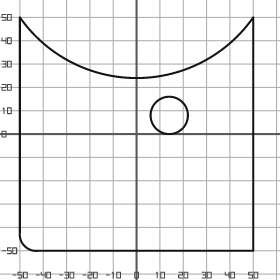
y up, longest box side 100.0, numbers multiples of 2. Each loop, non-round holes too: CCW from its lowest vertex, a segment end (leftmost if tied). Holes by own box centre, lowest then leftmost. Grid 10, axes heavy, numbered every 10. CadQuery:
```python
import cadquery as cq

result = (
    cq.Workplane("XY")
    .moveTo(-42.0, -50.0)
    .lineTo(50.0, -50.0)
    .lineTo(50.0, 50.0)
    .threePointArc((0.0, 24.0), (-50.0, 50.0))
    .lineTo(-50.0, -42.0)
    .threePointArc((-48.0, -48.0), (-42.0, -50.0))
    .close()
    .moveTo(14.0, 8.0)
    .circle(8.0)
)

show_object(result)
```